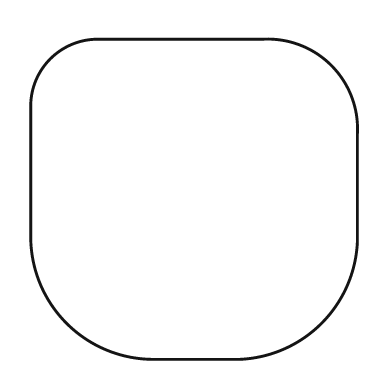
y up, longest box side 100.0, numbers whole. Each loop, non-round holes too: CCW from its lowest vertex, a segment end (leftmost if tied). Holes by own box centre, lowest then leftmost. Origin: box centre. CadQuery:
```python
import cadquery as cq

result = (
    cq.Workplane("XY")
    .moveTo(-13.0, -49.0)
    .lineTo(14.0, -49.0)
    .threePointArc((39.0, -38.0), (50.0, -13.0))
    .lineTo(50.0, 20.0)
    .threePointArc((42.0, 41.0), (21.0, 49.0))
    .lineTo(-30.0, 49.0)
    .threePointArc((-44.0, 43.0), (-50.0, 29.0))
    .lineTo(-50.0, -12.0)
    .threePointArc((-39.0, -38.0), (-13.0, -49.0))
    .close()
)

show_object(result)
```